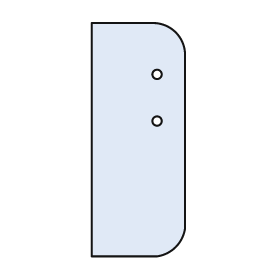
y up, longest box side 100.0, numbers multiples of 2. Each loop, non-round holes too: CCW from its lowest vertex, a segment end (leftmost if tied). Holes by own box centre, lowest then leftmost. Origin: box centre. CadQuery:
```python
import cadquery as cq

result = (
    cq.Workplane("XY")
    .moveTo(-20.0, -50.0)
    .lineTo(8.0, -50.0)
    .threePointArc((16.0, -46.0), (20.0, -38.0))
    .lineTo(20.0, 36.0)
    .threePointArc((16.0, 46.0), (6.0, 50.0))
    .lineTo(-20.0, 50.0)
    .close()
    .moveTo(8.0, 8.0)
    .circle(2.0)
    .moveTo(8.0, 28.0)
    .circle(2.0)
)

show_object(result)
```